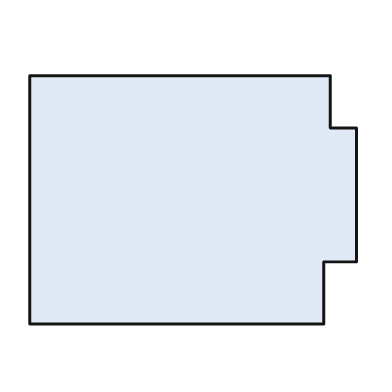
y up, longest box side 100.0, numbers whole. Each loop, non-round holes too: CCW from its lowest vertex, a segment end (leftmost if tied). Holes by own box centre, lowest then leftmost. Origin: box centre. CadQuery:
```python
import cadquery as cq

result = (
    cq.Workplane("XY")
    .moveTo(-50.0, -38.0)
    .lineTo(40.0, -38.0)
    .lineTo(40.0, -19.0)
    .lineTo(50.0, -19.0)
    .lineTo(50.0, 22.0)
    .lineTo(42.0, 22.0)
    .lineTo(42.0, 38.0)
    .lineTo(-50.0, 38.0)
    .close()
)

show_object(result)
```